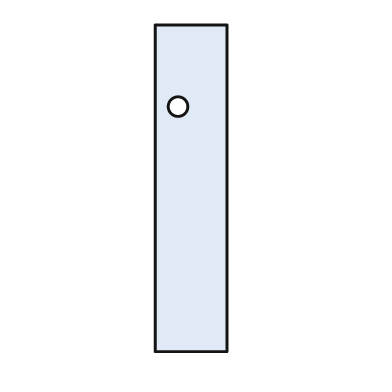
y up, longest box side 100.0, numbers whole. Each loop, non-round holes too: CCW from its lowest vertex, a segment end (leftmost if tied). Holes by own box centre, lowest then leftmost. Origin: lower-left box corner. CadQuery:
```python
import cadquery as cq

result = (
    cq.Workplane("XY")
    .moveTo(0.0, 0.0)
    .lineTo(22.0, 0.0)
    .lineTo(22.0, 100.0)
    .lineTo(0.0, 100.0)
    .close()
    .moveTo(7.0, 75.0)
    .circle(3.0)
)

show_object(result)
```